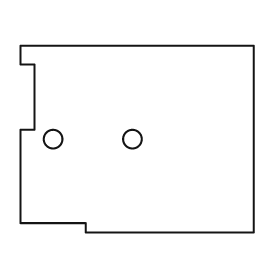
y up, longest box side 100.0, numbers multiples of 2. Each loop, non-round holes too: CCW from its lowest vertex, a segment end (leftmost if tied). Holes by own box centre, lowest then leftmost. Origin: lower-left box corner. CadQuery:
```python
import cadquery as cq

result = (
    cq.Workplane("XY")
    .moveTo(28.0, 0.0)
    .lineTo(100.0, 0.0)
    .lineTo(100.0, 80.0)
    .lineTo(0.0, 80.0)
    .lineTo(0.0, 72.0)
    .lineTo(6.0, 72.0)
    .lineTo(6.0, 44.0)
    .lineTo(0.0, 44.0)
    .lineTo(0.0, 4.0)
    .lineTo(28.0, 4.0)
    .close()
    .moveTo(14.0, 40.0)
    .circle(4.0)
    .moveTo(48.0, 40.0)
    .circle(4.0)
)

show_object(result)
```